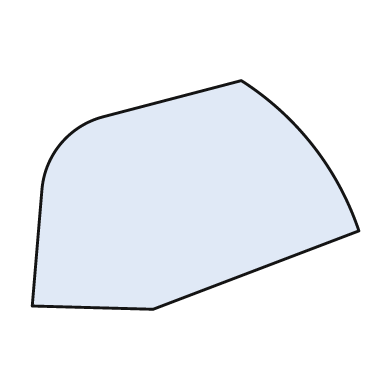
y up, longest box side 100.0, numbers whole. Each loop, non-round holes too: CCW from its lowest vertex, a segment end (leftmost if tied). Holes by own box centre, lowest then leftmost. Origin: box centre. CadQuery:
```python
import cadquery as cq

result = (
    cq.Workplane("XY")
    .moveTo(-13.0, -35.0)
    .lineTo(50.0, -11.0)
    .threePointArc((36.0, 15.0), (14.0, 35.0))
    .lineTo(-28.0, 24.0)
    .threePointArc((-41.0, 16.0), (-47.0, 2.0))
    .lineTo(-50.0, -34.0)
    .close()
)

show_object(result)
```